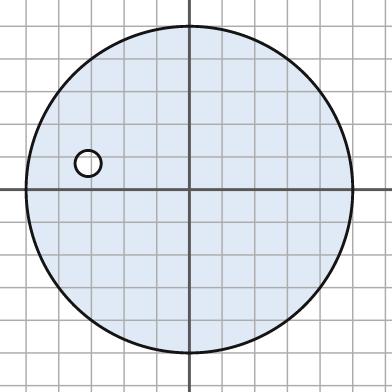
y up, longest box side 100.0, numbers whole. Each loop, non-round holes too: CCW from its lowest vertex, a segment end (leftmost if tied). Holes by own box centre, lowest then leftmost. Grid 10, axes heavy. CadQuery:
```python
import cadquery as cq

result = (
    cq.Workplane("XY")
    .moveTo(0.0, 0.0)
    .circle(50.0)
    .moveTo(-31.0, 8.0)
    .circle(4.0)
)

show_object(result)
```